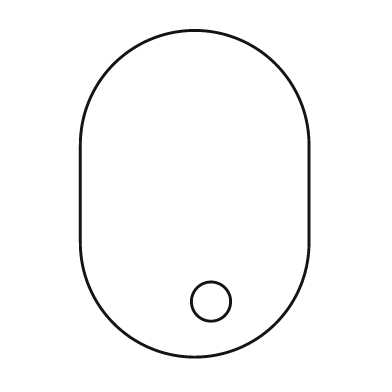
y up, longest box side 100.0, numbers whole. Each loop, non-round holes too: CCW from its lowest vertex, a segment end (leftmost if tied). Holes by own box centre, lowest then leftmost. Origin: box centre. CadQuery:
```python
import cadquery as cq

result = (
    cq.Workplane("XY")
    .moveTo(-35.0, -15.0)
    .threePointArc((0.0, -50.0), (35.0, -15.0))
    .lineTo(35.0, 15.0)
    .threePointArc((0.0, 50.0), (-35.0, 15.0))
    .close()
    .moveTo(5.0, -33.0)
    .circle(6.0)
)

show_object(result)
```